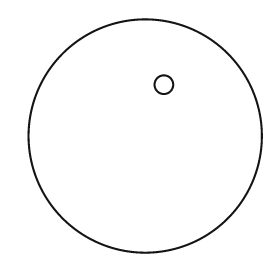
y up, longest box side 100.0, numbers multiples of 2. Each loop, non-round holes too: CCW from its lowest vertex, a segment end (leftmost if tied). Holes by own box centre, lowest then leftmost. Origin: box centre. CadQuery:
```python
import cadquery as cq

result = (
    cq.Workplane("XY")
    .moveTo(0.0, 0.0)
    .circle(50.0)
    .moveTo(8.0, 22.0)
    .circle(4.0)
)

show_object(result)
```